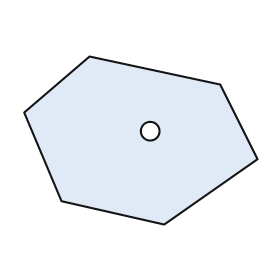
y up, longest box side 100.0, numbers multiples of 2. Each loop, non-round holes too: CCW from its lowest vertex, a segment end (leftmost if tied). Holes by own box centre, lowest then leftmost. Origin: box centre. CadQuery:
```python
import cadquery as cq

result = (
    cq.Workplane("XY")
    .moveTo(10.0, -36.0)
    .lineTo(50.0, -8.0)
    .lineTo(34.0, 24.0)
    .lineTo(-22.0, 36.0)
    .lineTo(-50.0, 12.0)
    .lineTo(-34.0, -26.0)
    .close()
    .moveTo(4.0, 4.0)
    .circle(4.0)
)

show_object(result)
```